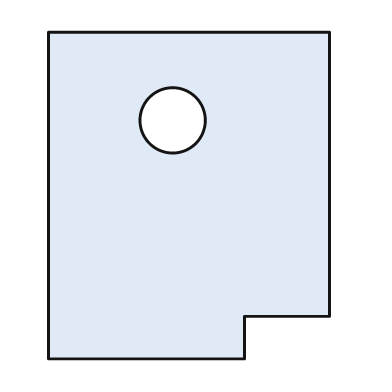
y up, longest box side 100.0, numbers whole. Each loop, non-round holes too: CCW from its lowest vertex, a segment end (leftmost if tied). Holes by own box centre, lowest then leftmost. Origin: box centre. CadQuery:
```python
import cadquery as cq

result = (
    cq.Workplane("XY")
    .moveTo(-43.0, -50.0)
    .lineTo(17.0, -50.0)
    .lineTo(17.0, -37.0)
    .lineTo(43.0, -37.0)
    .lineTo(43.0, 50.0)
    .lineTo(-43.0, 50.0)
    .close()
    .moveTo(-5.0, 23.0)
    .circle(10.0)
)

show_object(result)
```